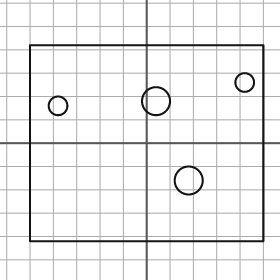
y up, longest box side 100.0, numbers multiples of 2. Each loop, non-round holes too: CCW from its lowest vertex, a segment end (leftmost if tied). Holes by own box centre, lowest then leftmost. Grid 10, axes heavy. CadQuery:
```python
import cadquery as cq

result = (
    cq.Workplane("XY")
    .moveTo(-50.0, -42.0)
    .lineTo(50.0, -42.0)
    .lineTo(50.0, 42.0)
    .lineTo(-50.0, 42.0)
    .close()
    .moveTo(18.0, -16.0)
    .circle(6.0)
    .moveTo(-38.0, 16.0)
    .circle(4.0)
    .moveTo(4.0, 18.0)
    .circle(6.0)
    .moveTo(42.0, 26.0)
    .circle(4.0)
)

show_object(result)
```